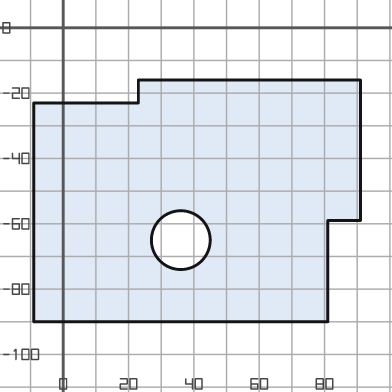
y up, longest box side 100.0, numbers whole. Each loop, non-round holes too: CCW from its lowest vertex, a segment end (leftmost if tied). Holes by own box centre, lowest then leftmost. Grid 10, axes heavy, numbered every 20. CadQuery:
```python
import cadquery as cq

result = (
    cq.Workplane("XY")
    .moveTo(-9.0, -90.0)
    .lineTo(81.0, -90.0)
    .lineTo(81.0, -59.0)
    .lineTo(91.0, -59.0)
    .lineTo(91.0, -16.0)
    .lineTo(23.0, -16.0)
    .lineTo(23.0, -23.0)
    .lineTo(-9.0, -23.0)
    .close()
    .moveTo(36.0, -65.0)
    .circle(9.0)
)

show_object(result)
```